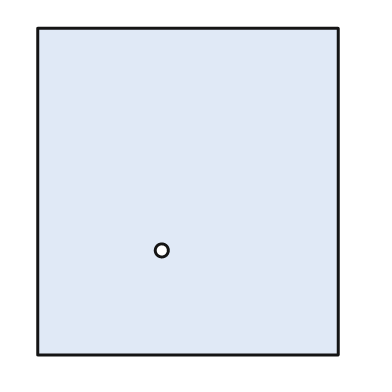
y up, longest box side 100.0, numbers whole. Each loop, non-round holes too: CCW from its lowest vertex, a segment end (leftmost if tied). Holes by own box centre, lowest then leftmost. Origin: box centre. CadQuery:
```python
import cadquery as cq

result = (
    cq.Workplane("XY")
    .moveTo(-46.0, -50.0)
    .lineTo(46.0, -50.0)
    .lineTo(46.0, 50.0)
    .lineTo(-46.0, 50.0)
    .close()
    .moveTo(-8.0, -18.0)
    .circle(2.0)
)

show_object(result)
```